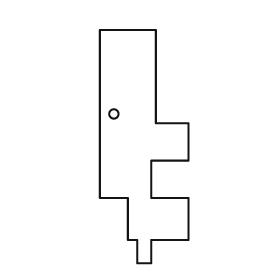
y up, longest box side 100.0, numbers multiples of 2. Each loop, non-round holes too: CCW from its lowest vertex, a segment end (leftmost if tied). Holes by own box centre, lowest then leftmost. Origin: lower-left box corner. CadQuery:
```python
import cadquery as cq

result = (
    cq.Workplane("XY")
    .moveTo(16.0, 0.0)
    .lineTo(22.0, 0.0)
    .lineTo(22.0, 10.0)
    .lineTo(38.0, 10.0)
    .lineTo(38.0, 28.0)
    .lineTo(22.0, 28.0)
    .lineTo(22.0, 44.0)
    .lineTo(38.0, 44.0)
    .lineTo(38.0, 60.0)
    .lineTo(24.0, 60.0)
    .lineTo(24.0, 100.0)
    .lineTo(0.0, 100.0)
    .lineTo(0.0, 28.0)
    .lineTo(12.0, 28.0)
    .lineTo(12.0, 10.0)
    .lineTo(16.0, 10.0)
    .close()
    .moveTo(6.0, 64.0)
    .circle(2.0)
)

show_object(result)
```